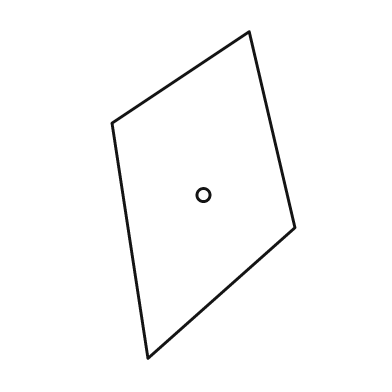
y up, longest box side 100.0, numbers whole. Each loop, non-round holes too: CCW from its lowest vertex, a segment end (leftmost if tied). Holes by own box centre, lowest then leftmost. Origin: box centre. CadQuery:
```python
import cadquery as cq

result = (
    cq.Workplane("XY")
    .moveTo(-17.0, -50.0)
    .lineTo(28.0, -10.0)
    .lineTo(14.0, 50.0)
    .lineTo(-28.0, 22.0)
    .close()
    .moveTo(0.0, 0.0)
    .circle(2.0)
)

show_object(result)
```